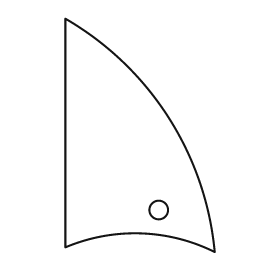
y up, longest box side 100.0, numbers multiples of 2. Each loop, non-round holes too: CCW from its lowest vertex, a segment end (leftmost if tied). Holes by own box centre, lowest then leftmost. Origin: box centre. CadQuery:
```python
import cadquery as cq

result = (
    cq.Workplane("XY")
    .moveTo(32.0, -50.0)
    .threePointArc((12.0, 8.0), (-32.0, 50.0))
    .lineTo(-32.0, -48.0)
    .threePointArc((0.0, -42.0), (32.0, -50.0))
    .close()
    .moveTo(8.0, -32.0)
    .circle(4.0)
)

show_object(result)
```